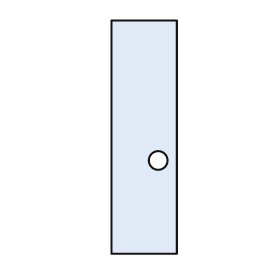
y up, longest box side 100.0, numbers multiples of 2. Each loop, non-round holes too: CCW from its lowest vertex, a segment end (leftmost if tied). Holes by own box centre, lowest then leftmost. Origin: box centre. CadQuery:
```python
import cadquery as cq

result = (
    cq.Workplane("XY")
    .moveTo(-14.0, -50.0)
    .lineTo(14.0, -50.0)
    .lineTo(14.0, 50.0)
    .lineTo(-14.0, 50.0)
    .close()
    .moveTo(6.0, -10.0)
    .circle(4.0)
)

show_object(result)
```